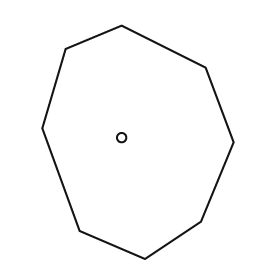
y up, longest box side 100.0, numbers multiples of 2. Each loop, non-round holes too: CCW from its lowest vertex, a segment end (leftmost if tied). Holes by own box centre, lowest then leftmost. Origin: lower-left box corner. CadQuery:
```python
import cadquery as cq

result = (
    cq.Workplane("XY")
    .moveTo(44.0, 0.0)
    .lineTo(68.0, 16.0)
    .lineTo(82.0, 50.0)
    .lineTo(70.0, 82.0)
    .lineTo(34.0, 100.0)
    .lineTo(10.0, 90.0)
    .lineTo(0.0, 56.0)
    .lineTo(16.0, 12.0)
    .close()
    .moveTo(34.0, 52.0)
    .circle(2.0)
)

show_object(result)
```